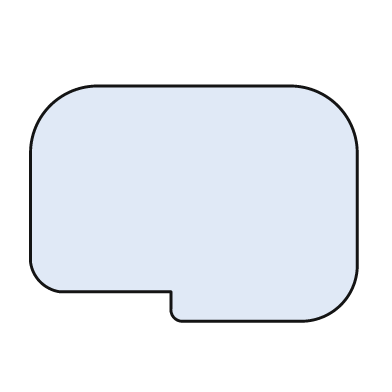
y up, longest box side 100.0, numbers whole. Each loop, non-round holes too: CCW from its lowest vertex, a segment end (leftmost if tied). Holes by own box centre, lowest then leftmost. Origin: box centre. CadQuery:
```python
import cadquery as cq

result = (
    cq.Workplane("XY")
    .moveTo(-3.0, -36.0)
    .lineTo(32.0, -36.0)
    .threePointArc((45.0, -31.0), (50.0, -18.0))
    .lineTo(50.0, 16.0)
    .threePointArc((44.0, 30.0), (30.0, 36.0))
    .lineTo(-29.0, 36.0)
    .threePointArc((-44.0, 30.0), (-50.0, 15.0))
    .lineTo(-50.0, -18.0)
    .threePointArc((-47.0, -24.0), (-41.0, -27.0))
    .lineTo(-7.0, -27.0)
    .lineTo(-7.0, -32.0)
    .threePointArc((-6.0, -35.0), (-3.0, -36.0))
    .close()
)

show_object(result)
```